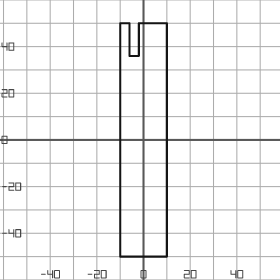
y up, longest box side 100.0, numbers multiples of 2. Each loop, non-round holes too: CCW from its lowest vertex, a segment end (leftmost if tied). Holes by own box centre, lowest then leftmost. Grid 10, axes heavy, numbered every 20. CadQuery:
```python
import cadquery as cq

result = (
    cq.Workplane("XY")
    .moveTo(-10.0, -50.0)
    .lineTo(10.0, -50.0)
    .lineTo(10.0, 50.0)
    .lineTo(-2.0, 50.0)
    .lineTo(-2.0, 36.0)
    .lineTo(-6.0, 36.0)
    .lineTo(-6.0, 50.0)
    .lineTo(-10.0, 50.0)
    .close()
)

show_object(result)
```